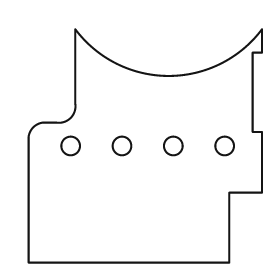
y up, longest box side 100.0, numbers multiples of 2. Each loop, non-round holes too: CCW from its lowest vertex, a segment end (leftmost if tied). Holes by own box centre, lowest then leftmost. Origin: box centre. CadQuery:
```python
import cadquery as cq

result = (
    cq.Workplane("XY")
    .moveTo(-50.0, -50.0)
    .lineTo(36.0, -50.0)
    .lineTo(36.0, -20.0)
    .lineTo(50.0, -20.0)
    .lineTo(50.0, 6.0)
    .lineTo(46.0, 6.0)
    .lineTo(46.0, 40.0)
    .lineTo(50.0, 40.0)
    .lineTo(50.0, 50.0)
    .threePointArc((10.0, 30.0), (-30.0, 50.0))
    .lineTo(-30.0, 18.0)
    .threePointArc((-32.0, 12.0), (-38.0, 10.0))
    .lineTo(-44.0, 10.0)
    .threePointArc((-48.0, 8.0), (-50.0, 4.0))
    .close()
    .moveTo(-32.0, 0.0)
    .circle(4.0)
    .moveTo(-10.0, 0.0)
    .circle(4.0)
    .moveTo(12.0, 0.0)
    .circle(4.0)
    .moveTo(34.0, 0.0)
    .circle(4.0)
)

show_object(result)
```